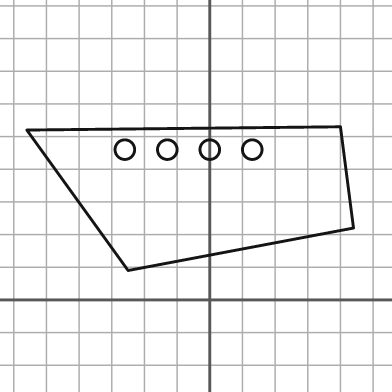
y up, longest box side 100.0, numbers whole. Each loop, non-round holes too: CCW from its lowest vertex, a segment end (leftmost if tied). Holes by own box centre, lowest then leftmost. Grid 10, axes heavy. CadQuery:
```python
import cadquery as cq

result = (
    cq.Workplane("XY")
    .moveTo(-25.0, 9.0)
    .lineTo(44.0, 22.0)
    .lineTo(40.0, 53.0)
    .lineTo(-56.0, 52.0)
    .close()
    .moveTo(-26.0, 46.0)
    .circle(3.0)
    .moveTo(-13.0, 46.0)
    .circle(3.0)
    .moveTo(0.0, 46.0)
    .circle(3.0)
    .moveTo(13.0, 46.0)
    .circle(3.0)
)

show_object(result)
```